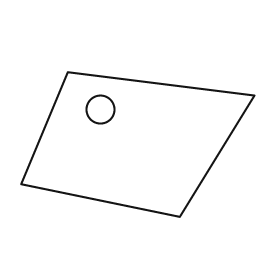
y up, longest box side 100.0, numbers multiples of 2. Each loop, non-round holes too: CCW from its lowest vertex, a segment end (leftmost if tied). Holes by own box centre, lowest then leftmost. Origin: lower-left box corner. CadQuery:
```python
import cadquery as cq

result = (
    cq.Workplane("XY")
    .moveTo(68.0, 0.0)
    .lineTo(100.0, 52.0)
    .lineTo(20.0, 62.0)
    .lineTo(0.0, 14.0)
    .close()
    .moveTo(34.0, 46.0)
    .circle(6.0)
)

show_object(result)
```